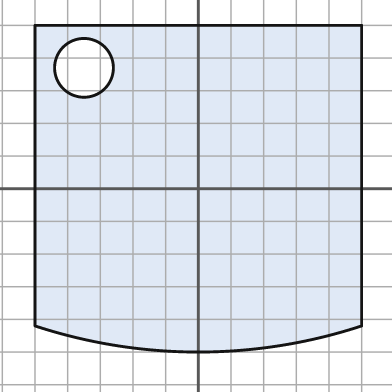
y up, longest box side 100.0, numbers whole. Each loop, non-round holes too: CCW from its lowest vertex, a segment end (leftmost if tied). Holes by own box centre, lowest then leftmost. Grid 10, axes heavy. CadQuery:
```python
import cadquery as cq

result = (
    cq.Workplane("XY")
    .moveTo(-50.0, -42.0)
    .threePointArc((0.0, -50.0), (50.0, -42.0))
    .lineTo(50.0, 50.0)
    .lineTo(-50.0, 50.0)
    .close()
    .moveTo(-35.0, 37.0)
    .circle(9.0)
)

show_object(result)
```